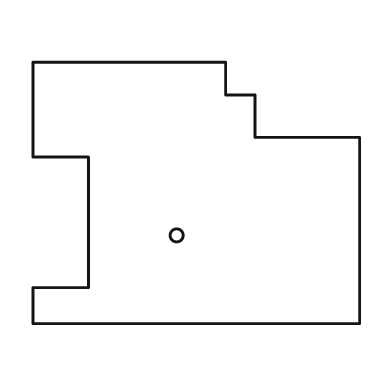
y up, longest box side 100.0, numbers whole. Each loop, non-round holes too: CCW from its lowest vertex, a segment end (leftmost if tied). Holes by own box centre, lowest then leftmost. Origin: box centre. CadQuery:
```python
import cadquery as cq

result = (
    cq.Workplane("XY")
    .moveTo(-50.0, -40.0)
    .lineTo(50.0, -40.0)
    .lineTo(50.0, 17.0)
    .lineTo(18.0, 17.0)
    .lineTo(18.0, 30.0)
    .lineTo(9.0, 30.0)
    .lineTo(9.0, 40.0)
    .lineTo(-50.0, 40.0)
    .lineTo(-50.0, 11.0)
    .lineTo(-33.0, 11.0)
    .lineTo(-33.0, -29.0)
    .lineTo(-50.0, -29.0)
    .close()
    .moveTo(-6.0, -13.0)
    .circle(2.0)
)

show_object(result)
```